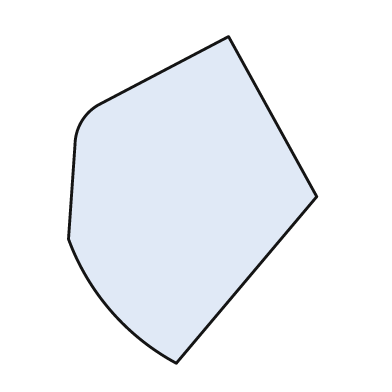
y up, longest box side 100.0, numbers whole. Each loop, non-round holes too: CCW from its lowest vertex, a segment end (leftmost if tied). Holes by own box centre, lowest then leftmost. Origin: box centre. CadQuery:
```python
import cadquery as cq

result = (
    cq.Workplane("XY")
    .moveTo(-5.0, -50.0)
    .lineTo(38.0, 1.0)
    .lineTo(11.0, 50.0)
    .lineTo(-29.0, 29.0)
    .threePointArc((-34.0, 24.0), (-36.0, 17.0))
    .lineTo(-38.0, -12.0)
    .threePointArc((-25.0, -34.0), (-5.0, -50.0))
    .close()
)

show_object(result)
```